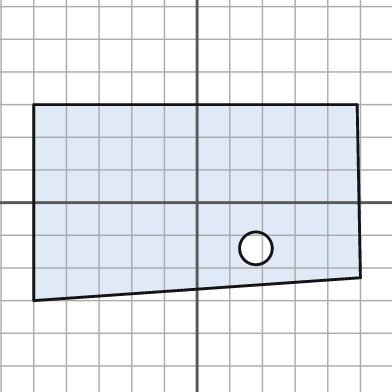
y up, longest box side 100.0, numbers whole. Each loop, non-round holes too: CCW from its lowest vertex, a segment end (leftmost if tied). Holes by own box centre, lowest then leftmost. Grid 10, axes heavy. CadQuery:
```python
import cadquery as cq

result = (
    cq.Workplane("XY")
    .moveTo(-50.0, -30.0)
    .lineTo(50.0, -23.0)
    .lineTo(49.0, 30.0)
    .lineTo(-50.0, 30.0)
    .close()
    .moveTo(18.0, -14.0)
    .circle(5.0)
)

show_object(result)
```